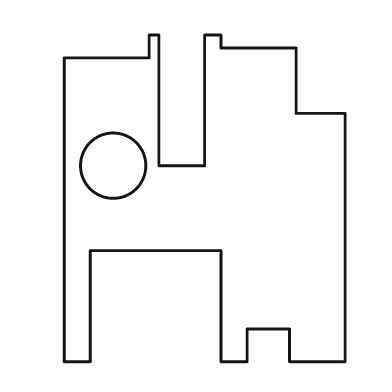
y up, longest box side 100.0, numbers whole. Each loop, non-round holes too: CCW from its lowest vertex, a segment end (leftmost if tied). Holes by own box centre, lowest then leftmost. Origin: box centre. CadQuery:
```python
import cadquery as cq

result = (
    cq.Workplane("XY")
    .moveTo(-43.0, -50.0)
    .lineTo(-35.0, -50.0)
    .lineTo(-35.0, -16.0)
    .lineTo(5.0, -16.0)
    .lineTo(5.0, -50.0)
    .lineTo(13.0, -50.0)
    .lineTo(13.0, -40.0)
    .lineTo(26.0, -40.0)
    .lineTo(26.0, -50.0)
    .lineTo(43.0, -50.0)
    .lineTo(43.0, 26.0)
    .lineTo(28.0, 26.0)
    .lineTo(28.0, 46.0)
    .lineTo(5.0, 46.0)
    .lineTo(5.0, 50.0)
    .lineTo(0.0, 50.0)
    .lineTo(0.0, 10.0)
    .lineTo(-14.0, 10.0)
    .lineTo(-14.0, 50.0)
    .lineTo(-17.0, 50.0)
    .lineTo(-17.0, 43.0)
    .lineTo(-43.0, 43.0)
    .close()
    .moveTo(-28.0, 10.0)
    .circle(10.0)
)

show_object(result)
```